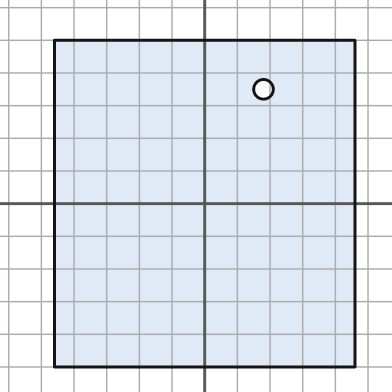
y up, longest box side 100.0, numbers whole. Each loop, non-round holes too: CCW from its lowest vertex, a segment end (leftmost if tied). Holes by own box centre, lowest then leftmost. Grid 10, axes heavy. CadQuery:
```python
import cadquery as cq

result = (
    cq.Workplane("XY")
    .moveTo(-46.0, -50.0)
    .lineTo(46.0, -50.0)
    .lineTo(46.0, 50.0)
    .lineTo(-46.0, 50.0)
    .close()
    .moveTo(18.0, 35.0)
    .circle(3.0)
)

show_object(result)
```